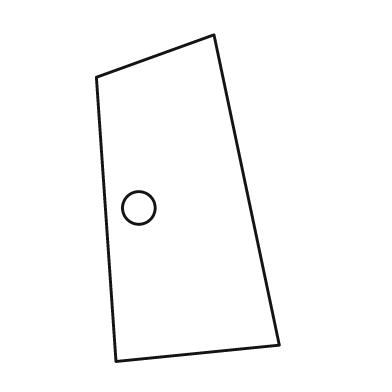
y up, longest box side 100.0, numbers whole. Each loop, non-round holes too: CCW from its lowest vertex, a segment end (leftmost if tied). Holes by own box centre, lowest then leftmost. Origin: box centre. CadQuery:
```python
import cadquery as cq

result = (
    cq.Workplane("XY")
    .moveTo(-22.0, -50.0)
    .lineTo(28.0, -45.0)
    .lineTo(8.0, 50.0)
    .lineTo(-28.0, 37.0)
    .close()
    .moveTo(-15.0, -3.0)
    .circle(5.0)
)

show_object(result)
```